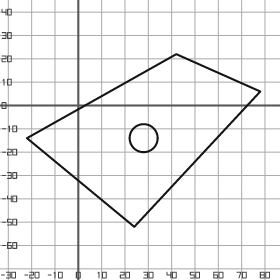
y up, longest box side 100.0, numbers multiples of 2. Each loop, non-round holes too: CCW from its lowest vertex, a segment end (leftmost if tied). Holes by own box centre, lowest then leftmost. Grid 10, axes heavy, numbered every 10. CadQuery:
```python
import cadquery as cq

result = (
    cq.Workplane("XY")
    .moveTo(24.0, -52.0)
    .lineTo(78.0, 6.0)
    .lineTo(42.0, 22.0)
    .lineTo(-22.0, -14.0)
    .close()
    .moveTo(28.0, -14.0)
    .circle(6.0)
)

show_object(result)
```